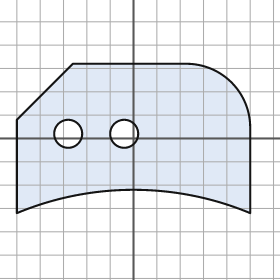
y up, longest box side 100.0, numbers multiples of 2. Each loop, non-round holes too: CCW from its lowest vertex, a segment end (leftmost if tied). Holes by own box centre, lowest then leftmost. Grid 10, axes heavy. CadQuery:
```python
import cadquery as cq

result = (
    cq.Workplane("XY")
    .moveTo(-50.0, -32.0)
    .threePointArc((0.0, -22.0), (50.0, -32.0))
    .lineTo(50.0, 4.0)
    .threePointArc((42.0, 24.0), (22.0, 32.0))
    .lineTo(-26.0, 32.0)
    .lineTo(-50.0, 8.0)
    .close()
    .moveTo(-28.0, 2.0)
    .circle(6.0)
    .moveTo(-4.0, 2.0)
    .circle(6.0)
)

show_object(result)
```